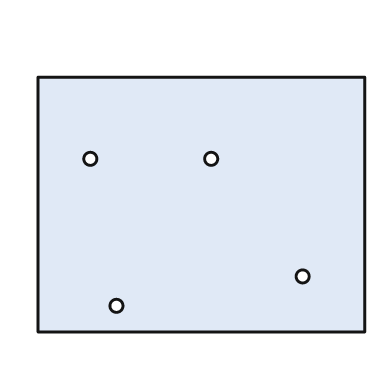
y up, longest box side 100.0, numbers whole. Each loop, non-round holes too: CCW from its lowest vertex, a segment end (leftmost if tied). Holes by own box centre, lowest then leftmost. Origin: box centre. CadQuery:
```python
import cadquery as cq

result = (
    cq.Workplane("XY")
    .moveTo(-50.0, -39.0)
    .lineTo(50.0, -39.0)
    .lineTo(50.0, 39.0)
    .lineTo(-50.0, 39.0)
    .close()
    .moveTo(-26.0, -31.0)
    .circle(2.0)
    .moveTo(31.0, -22.0)
    .circle(2.0)
    .moveTo(-34.0, 14.0)
    .circle(2.0)
    .moveTo(3.0, 14.0)
    .circle(2.0)
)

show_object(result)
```